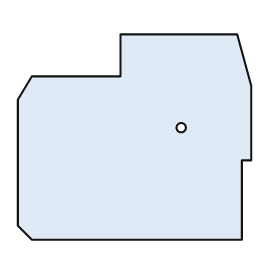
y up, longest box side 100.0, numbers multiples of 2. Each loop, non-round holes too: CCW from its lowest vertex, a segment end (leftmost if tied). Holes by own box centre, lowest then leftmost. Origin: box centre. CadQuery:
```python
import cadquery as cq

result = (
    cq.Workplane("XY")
    .moveTo(-44.0, -44.0)
    .lineTo(46.0, -44.0)
    .lineTo(46.0, -10.0)
    .lineTo(50.0, -10.0)
    .lineTo(50.0, 22.0)
    .lineTo(44.0, 44.0)
    .lineTo(-6.0, 44.0)
    .lineTo(-6.0, 26.0)
    .lineTo(-44.0, 26.0)
    .lineTo(-50.0, 16.0)
    .lineTo(-50.0, -38.0)
    .close()
    .moveTo(20.0, 4.0)
    .circle(2.0)
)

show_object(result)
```